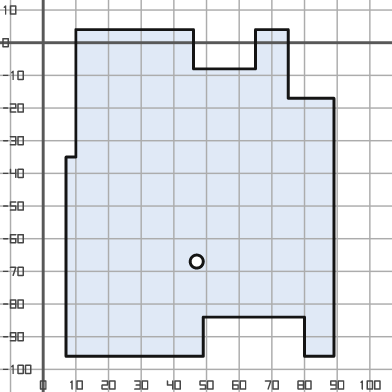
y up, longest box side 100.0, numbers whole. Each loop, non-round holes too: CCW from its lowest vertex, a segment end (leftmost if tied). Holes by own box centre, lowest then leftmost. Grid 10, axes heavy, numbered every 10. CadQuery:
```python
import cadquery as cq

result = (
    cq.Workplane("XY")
    .moveTo(7.0, -96.0)
    .lineTo(49.0, -96.0)
    .lineTo(49.0, -84.0)
    .lineTo(80.0, -84.0)
    .lineTo(80.0, -96.0)
    .lineTo(89.0, -96.0)
    .lineTo(89.0, -17.0)
    .lineTo(75.0, -17.0)
    .lineTo(75.0, 4.0)
    .lineTo(65.0, 4.0)
    .lineTo(65.0, -8.0)
    .lineTo(46.0, -8.0)
    .lineTo(46.0, 4.0)
    .lineTo(10.0, 4.0)
    .lineTo(10.0, -35.0)
    .lineTo(7.0, -35.0)
    .close()
    .moveTo(47.0, -67.0)
    .circle(2.0)
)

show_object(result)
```